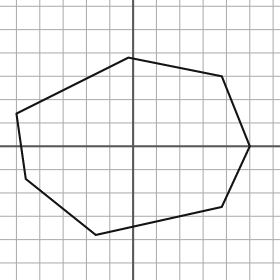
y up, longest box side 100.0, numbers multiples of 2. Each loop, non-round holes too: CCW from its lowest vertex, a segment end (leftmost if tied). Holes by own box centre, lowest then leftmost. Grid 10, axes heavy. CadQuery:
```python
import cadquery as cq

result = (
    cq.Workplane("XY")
    .moveTo(-16.0, -38.0)
    .lineTo(38.0, -26.0)
    .lineTo(50.0, 0.0)
    .lineTo(38.0, 30.0)
    .lineTo(-2.0, 38.0)
    .lineTo(-50.0, 14.0)
    .lineTo(-46.0, -14.0)
    .close()
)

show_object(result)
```